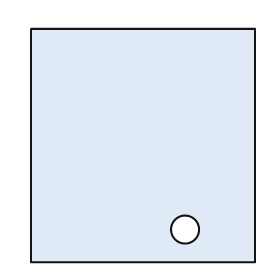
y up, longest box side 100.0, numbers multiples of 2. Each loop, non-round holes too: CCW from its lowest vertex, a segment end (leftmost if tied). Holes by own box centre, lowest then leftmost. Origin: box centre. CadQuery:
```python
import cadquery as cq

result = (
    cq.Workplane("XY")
    .moveTo(-48.0, -50.0)
    .lineTo(48.0, -50.0)
    .lineTo(48.0, 50.0)
    .lineTo(-48.0, 50.0)
    .close()
    .moveTo(18.0, -36.0)
    .circle(6.0)
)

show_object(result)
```